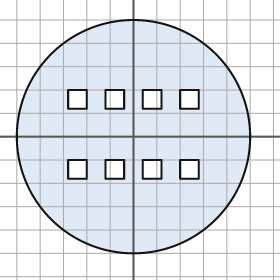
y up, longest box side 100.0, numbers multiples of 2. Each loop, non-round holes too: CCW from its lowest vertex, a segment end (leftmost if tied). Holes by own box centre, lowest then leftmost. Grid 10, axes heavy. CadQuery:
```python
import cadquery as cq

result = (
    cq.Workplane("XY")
    .moveTo(0.0, 0.0)
    .circle(50.0)
    .moveTo(-28.0, -18.0)
    .lineTo(-20.0, -18.0)
    .lineTo(-20.0, -10.0)
    .lineTo(-28.0, -10.0)
    .close()
    .moveTo(-12.0, -18.0)
    .lineTo(-4.0, -18.0)
    .lineTo(-4.0, -10.0)
    .lineTo(-12.0, -10.0)
    .close()
    .moveTo(4.0, -18.0)
    .lineTo(12.0, -18.0)
    .lineTo(12.0, -10.0)
    .lineTo(4.0, -10.0)
    .close()
    .moveTo(20.0, -18.0)
    .lineTo(28.0, -18.0)
    .lineTo(28.0, -10.0)
    .lineTo(20.0, -10.0)
    .close()
    .moveTo(-28.0, 12.0)
    .lineTo(-20.0, 12.0)
    .lineTo(-20.0, 20.0)
    .lineTo(-28.0, 20.0)
    .close()
    .moveTo(-12.0, 12.0)
    .lineTo(-4.0, 12.0)
    .lineTo(-4.0, 20.0)
    .lineTo(-12.0, 20.0)
    .close()
    .moveTo(4.0, 12.0)
    .lineTo(12.0, 12.0)
    .lineTo(12.0, 20.0)
    .lineTo(4.0, 20.0)
    .close()
    .moveTo(20.0, 12.0)
    .lineTo(28.0, 12.0)
    .lineTo(28.0, 20.0)
    .lineTo(20.0, 20.0)
    .close()
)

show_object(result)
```